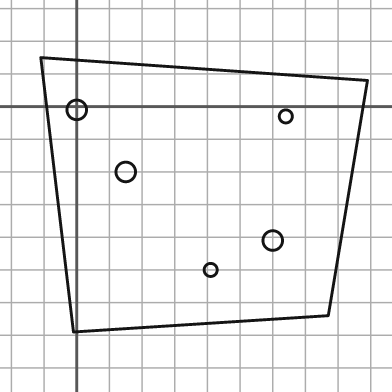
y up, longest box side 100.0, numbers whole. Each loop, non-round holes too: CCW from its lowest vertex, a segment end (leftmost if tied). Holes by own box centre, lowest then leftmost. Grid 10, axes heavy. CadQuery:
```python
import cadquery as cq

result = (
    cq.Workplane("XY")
    .moveTo(-1.0, -69.0)
    .lineTo(77.0, -64.0)
    .lineTo(89.0, 8.0)
    .lineTo(-11.0, 15.0)
    .close()
    .moveTo(41.0, -50.0)
    .circle(2.0)
    .moveTo(60.0, -41.0)
    .circle(3.0)
    .moveTo(15.0, -20.0)
    .circle(3.0)
    .moveTo(64.0, -3.0)
    .circle(2.0)
    .moveTo(0.0, -1.0)
    .circle(3.0)
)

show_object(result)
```